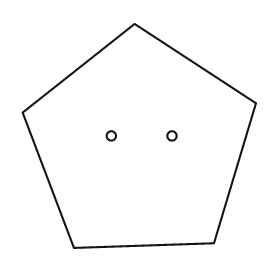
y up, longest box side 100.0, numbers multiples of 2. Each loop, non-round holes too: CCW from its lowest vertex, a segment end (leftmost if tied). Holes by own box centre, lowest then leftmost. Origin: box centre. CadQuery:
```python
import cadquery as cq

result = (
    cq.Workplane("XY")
    .moveTo(-28.0, -48.0)
    .lineTo(32.0, -46.0)
    .lineTo(50.0, 14.0)
    .lineTo(-2.0, 48.0)
    .lineTo(-50.0, 10.0)
    .close()
    .moveTo(-12.0, 0.0)
    .circle(2.0)
    .moveTo(14.0, 0.0)
    .circle(2.0)
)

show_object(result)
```